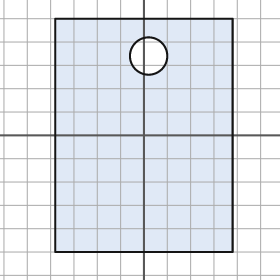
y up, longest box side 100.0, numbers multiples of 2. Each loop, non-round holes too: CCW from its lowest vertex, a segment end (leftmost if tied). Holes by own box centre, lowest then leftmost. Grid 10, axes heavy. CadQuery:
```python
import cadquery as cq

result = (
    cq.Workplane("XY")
    .moveTo(-38.0, -50.0)
    .lineTo(38.0, -50.0)
    .lineTo(38.0, 50.0)
    .lineTo(-38.0, 50.0)
    .close()
    .moveTo(2.0, 34.0)
    .circle(8.0)
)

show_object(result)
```